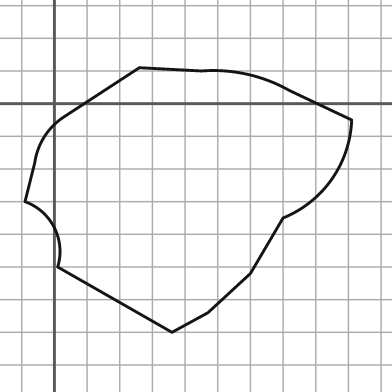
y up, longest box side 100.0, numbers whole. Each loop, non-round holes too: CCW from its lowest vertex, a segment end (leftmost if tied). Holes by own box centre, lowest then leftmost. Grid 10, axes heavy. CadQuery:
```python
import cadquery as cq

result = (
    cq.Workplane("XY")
    .moveTo(36.0, -70.0)
    .lineTo(47.0, -64.0)
    .lineTo(60.0, -52.0)
    .lineTo(70.0, -35.0)
    .threePointArc((85.0, -23.0), (91.0, -5.0))
    .lineTo(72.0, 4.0)
    .threePointArc((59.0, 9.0), (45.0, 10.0))
    .lineTo(26.0, 11.0)
    .lineTo(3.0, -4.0)
    .threePointArc((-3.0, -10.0), (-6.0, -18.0))
    .lineTo(-9.0, -30.0)
    .threePointArc((0.0, -38.0), (1.0, -50.0))
    .close()
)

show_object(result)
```